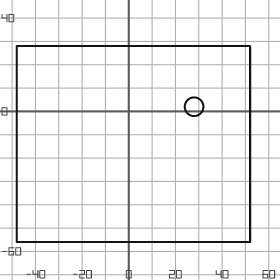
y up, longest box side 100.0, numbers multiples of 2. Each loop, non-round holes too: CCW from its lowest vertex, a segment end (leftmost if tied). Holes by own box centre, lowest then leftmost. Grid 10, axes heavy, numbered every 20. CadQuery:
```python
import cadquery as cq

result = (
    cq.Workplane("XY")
    .moveTo(-48.0, -56.0)
    .lineTo(52.0, -56.0)
    .lineTo(52.0, 28.0)
    .lineTo(-48.0, 28.0)
    .close()
    .moveTo(28.0, 2.0)
    .circle(4.0)
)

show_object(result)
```